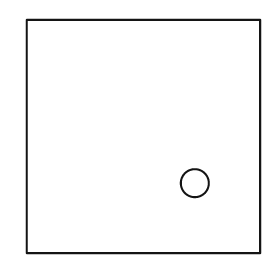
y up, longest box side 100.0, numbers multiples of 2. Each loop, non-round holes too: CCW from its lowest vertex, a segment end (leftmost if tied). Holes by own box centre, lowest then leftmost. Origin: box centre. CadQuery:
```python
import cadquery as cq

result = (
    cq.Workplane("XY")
    .moveTo(-50.0, -50.0)
    .lineTo(50.0, -50.0)
    .lineTo(50.0, 50.0)
    .lineTo(-50.0, 50.0)
    .close()
    .moveTo(22.0, -20.0)
    .circle(6.0)
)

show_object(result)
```